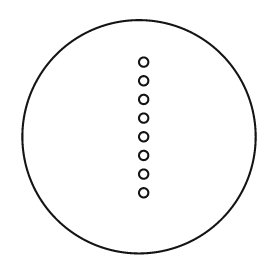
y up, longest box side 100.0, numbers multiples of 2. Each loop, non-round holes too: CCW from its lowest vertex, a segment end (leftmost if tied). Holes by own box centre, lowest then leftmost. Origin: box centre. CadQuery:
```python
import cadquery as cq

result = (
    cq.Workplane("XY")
    .moveTo(0.0, 0.0)
    .circle(50.0)
    .moveTo(2.0, -24.0)
    .circle(2.0)
    .moveTo(2.0, -16.0)
    .circle(2.0)
    .moveTo(2.0, -8.0)
    .circle(2.0)
    .moveTo(2.0, 0.0)
    .circle(2.0)
    .moveTo(2.0, 8.0)
    .circle(2.0)
    .moveTo(2.0, 16.0)
    .circle(2.0)
    .moveTo(2.0, 24.0)
    .circle(2.0)
    .moveTo(2.0, 32.0)
    .circle(2.0)
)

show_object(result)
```